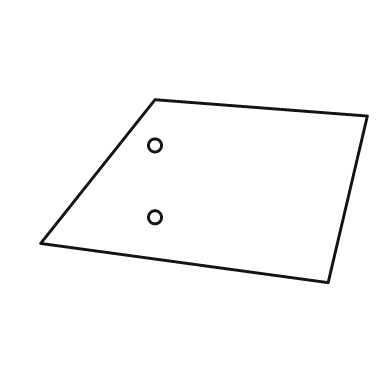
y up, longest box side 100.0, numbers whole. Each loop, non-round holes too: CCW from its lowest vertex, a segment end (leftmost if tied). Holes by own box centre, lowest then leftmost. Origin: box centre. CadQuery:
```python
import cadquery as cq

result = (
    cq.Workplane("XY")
    .moveTo(38.0, -28.0)
    .lineTo(50.0, 23.0)
    .lineTo(-15.0, 28.0)
    .lineTo(-50.0, -16.0)
    .close()
    .moveTo(-15.0, -8.0)
    .circle(2.0)
    .moveTo(-15.0, 14.0)
    .circle(2.0)
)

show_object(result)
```